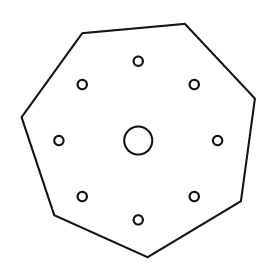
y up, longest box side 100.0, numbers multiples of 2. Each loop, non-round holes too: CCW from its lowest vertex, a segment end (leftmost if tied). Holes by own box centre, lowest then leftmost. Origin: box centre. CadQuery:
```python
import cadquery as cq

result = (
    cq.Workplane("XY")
    .moveTo(4.0, -50.0)
    .lineTo(44.0, -26.0)
    .lineTo(50.0, 18.0)
    .lineTo(20.0, 50.0)
    .lineTo(-24.0, 46.0)
    .lineTo(-50.0, 10.0)
    .lineTo(-36.0, -32.0)
    .close()
    .moveTo(0.0, -34.0)
    .circle(2.0)
    .moveTo(-24.0, -24.0)
    .circle(2.0)
    .moveTo(24.0, -24.0)
    .circle(2.0)
    .moveTo(-34.0, 0.0)
    .circle(2.0)
    .moveTo(0.0, 0.0)
    .circle(6.0)
    .moveTo(34.0, 0.0)
    .circle(2.0)
    .moveTo(-24.0, 24.0)
    .circle(2.0)
    .moveTo(24.0, 24.0)
    .circle(2.0)
    .moveTo(0.0, 34.0)
    .circle(2.0)
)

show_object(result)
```